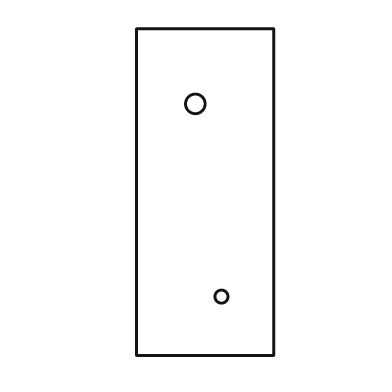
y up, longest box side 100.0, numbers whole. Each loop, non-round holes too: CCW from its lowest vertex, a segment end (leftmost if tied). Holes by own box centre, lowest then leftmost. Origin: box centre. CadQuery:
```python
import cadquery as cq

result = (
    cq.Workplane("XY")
    .moveTo(-21.0, -50.0)
    .lineTo(21.0, -50.0)
    .lineTo(21.0, 50.0)
    .lineTo(-21.0, 50.0)
    .close()
    .moveTo(5.0, -32.0)
    .circle(2.0)
    .moveTo(-3.0, 27.0)
    .circle(3.0)
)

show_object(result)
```